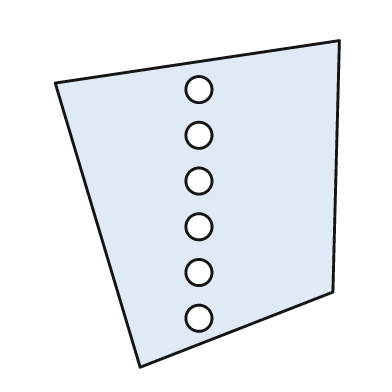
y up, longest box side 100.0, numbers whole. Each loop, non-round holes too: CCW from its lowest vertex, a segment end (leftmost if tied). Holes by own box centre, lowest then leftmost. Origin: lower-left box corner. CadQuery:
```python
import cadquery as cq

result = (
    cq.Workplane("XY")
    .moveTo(26.0, 0.0)
    .lineTo(85.0, 23.0)
    .lineTo(87.0, 100.0)
    .lineTo(0.0, 87.0)
    .close()
    .moveTo(44.0, 15.0)
    .circle(4.0)
    .moveTo(44.0, 29.0)
    .circle(4.0)
    .moveTo(44.0, 43.0)
    .circle(4.0)
    .moveTo(44.0, 57.0)
    .circle(4.0)
    .moveTo(44.0, 71.0)
    .circle(4.0)
    .moveTo(44.0, 85.0)
    .circle(4.0)
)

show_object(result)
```